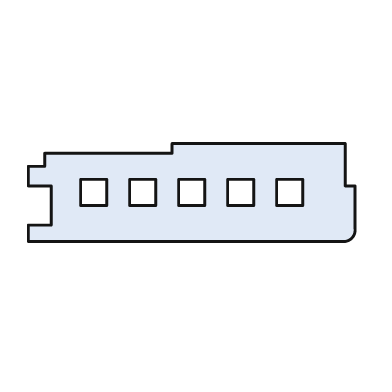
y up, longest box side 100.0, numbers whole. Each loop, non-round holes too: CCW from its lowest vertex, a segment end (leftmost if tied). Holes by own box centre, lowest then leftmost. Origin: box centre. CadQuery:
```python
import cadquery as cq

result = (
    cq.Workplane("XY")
    .moveTo(-50.0, -15.0)
    .lineTo(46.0, -15.0)
    .threePointArc((49.0, -14.0), (50.0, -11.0))
    .lineTo(50.0, 2.0)
    .lineTo(47.0, 2.0)
    .lineTo(47.0, 15.0)
    .lineTo(-6.0, 15.0)
    .lineTo(-6.0, 12.0)
    .lineTo(-45.0, 12.0)
    .lineTo(-45.0, 8.0)
    .lineTo(-50.0, 8.0)
    .lineTo(-50.0, 2.0)
    .lineTo(-43.0, 2.0)
    .lineTo(-43.0, -10.0)
    .lineTo(-50.0, -10.0)
    .close()
    .moveTo(-34.0, -4.0)
    .lineTo(-26.0, -4.0)
    .lineTo(-26.0, 4.0)
    .lineTo(-34.0, 4.0)
    .close()
    .moveTo(-19.0, -4.0)
    .lineTo(-11.0, -4.0)
    .lineTo(-11.0, 4.0)
    .lineTo(-19.0, 4.0)
    .close()
    .moveTo(-4.0, -4.0)
    .lineTo(4.0, -4.0)
    .lineTo(4.0, 4.0)
    .lineTo(-4.0, 4.0)
    .close()
    .moveTo(11.0, -4.0)
    .lineTo(19.0, -4.0)
    .lineTo(19.0, 4.0)
    .lineTo(11.0, 4.0)
    .close()
    .moveTo(26.0, -4.0)
    .lineTo(34.0, -4.0)
    .lineTo(34.0, 4.0)
    .lineTo(26.0, 4.0)
    .close()
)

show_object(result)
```